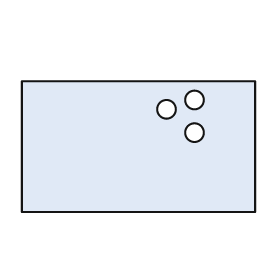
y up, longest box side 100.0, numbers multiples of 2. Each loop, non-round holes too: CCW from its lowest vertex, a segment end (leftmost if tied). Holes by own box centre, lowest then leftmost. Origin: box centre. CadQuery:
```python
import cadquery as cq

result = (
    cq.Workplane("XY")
    .moveTo(-50.0, -28.0)
    .lineTo(50.0, -28.0)
    .lineTo(50.0, 28.0)
    .lineTo(-50.0, 28.0)
    .close()
    .moveTo(24.0, 6.0)
    .circle(4.0)
    .moveTo(12.0, 16.0)
    .circle(4.0)
    .moveTo(24.0, 20.0)
    .circle(4.0)
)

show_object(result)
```